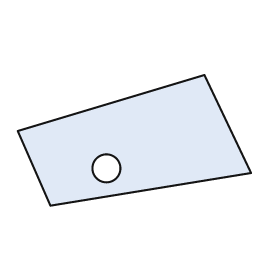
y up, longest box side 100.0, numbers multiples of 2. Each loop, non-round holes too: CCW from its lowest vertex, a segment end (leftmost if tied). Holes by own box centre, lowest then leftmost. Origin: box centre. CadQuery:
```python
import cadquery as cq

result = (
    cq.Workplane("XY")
    .moveTo(-36.0, -28.0)
    .lineTo(50.0, -14.0)
    .lineTo(30.0, 28.0)
    .lineTo(-50.0, 4.0)
    .close()
    .moveTo(-12.0, -12.0)
    .circle(6.0)
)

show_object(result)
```